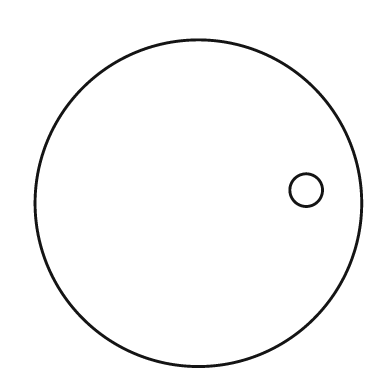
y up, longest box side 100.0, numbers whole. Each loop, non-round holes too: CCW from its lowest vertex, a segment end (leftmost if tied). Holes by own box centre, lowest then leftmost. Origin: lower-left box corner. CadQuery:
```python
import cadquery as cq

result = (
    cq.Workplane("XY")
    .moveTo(50.0, 50.0)
    .circle(50.0)
    .moveTo(83.0, 54.0)
    .circle(5.0)
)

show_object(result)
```